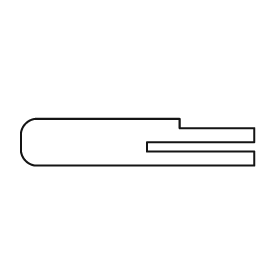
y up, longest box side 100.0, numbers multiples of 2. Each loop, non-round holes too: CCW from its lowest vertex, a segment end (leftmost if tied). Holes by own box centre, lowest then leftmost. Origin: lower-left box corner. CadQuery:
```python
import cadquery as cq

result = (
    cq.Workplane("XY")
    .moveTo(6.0, 0.0)
    .lineTo(100.0, 0.0)
    .lineTo(100.0, 6.0)
    .lineTo(54.0, 6.0)
    .lineTo(54.0, 10.0)
    .lineTo(100.0, 10.0)
    .lineTo(100.0, 16.0)
    .lineTo(68.0, 16.0)
    .lineTo(68.0, 20.0)
    .lineTo(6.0, 20.0)
    .threePointArc((2.0, 18.0), (0.0, 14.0))
    .lineTo(0.0, 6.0)
    .threePointArc((2.0, 2.0), (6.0, 0.0))
    .close()
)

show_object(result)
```